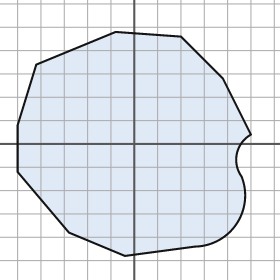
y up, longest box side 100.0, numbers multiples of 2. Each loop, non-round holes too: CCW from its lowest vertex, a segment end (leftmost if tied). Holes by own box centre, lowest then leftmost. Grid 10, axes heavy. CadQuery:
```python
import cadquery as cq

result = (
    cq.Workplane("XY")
    .moveTo(-4.0, -48.0)
    .lineTo(26.0, -44.0)
    .threePointArc((44.0, -34.0), (46.0, -14.0))
    .threePointArc((44.0, -4.0), (50.0, 4.0))
    .lineTo(38.0, 28.0)
    .lineTo(20.0, 46.0)
    .lineTo(-8.0, 48.0)
    .lineTo(-42.0, 34.0)
    .lineTo(-50.0, 8.0)
    .lineTo(-50.0, -12.0)
    .lineTo(-28.0, -38.0)
    .close()
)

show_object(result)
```